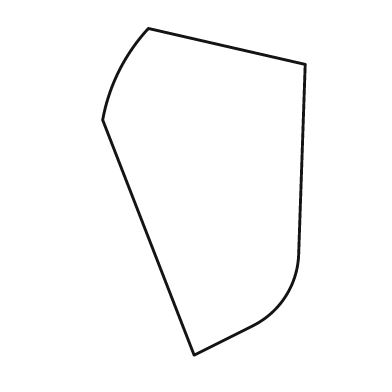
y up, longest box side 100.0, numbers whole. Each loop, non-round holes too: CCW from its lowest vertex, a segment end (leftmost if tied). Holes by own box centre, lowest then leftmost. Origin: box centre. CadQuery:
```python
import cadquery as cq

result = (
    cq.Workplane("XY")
    .moveTo(-3.0, -50.0)
    .lineTo(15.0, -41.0)
    .threePointArc((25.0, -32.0), (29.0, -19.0))
    .lineTo(31.0, 39.0)
    .lineTo(-17.0, 50.0)
    .threePointArc((-26.0, 37.0), (-31.0, 22.0))
    .close()
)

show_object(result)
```